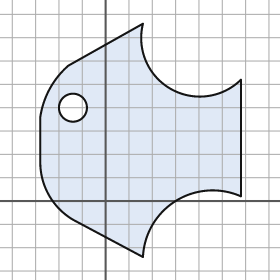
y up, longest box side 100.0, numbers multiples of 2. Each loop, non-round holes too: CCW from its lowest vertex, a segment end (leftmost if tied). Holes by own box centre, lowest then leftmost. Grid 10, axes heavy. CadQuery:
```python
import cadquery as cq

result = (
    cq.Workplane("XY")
    .moveTo(16.0, -24.0)
    .threePointArc((30.0, 0.0), (58.0, 2.0))
    .lineTo(58.0, 52.0)
    .threePointArc((28.0, 48.0), (16.0, 76.0))
    .lineTo(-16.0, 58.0)
    .threePointArc((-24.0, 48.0), (-28.0, 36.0))
    .lineTo(-28.0, 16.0)
    .threePointArc((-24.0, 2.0), (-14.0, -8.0))
    .close()
    .moveTo(-14.0, 40.0)
    .circle(6.0)
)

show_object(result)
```